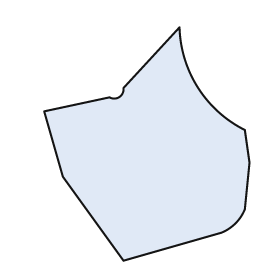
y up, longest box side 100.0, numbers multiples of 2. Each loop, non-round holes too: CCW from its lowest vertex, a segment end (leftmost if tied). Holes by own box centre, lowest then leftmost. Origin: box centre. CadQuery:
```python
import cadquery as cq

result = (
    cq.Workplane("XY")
    .moveTo(-10.0, -50.0)
    .lineTo(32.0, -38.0)
    .threePointArc((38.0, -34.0), (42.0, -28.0))
    .lineTo(44.0, -8.0)
    .lineTo(42.0, 6.0)
    .threePointArc((22.0, 24.0), (14.0, 50.0))
    .lineTo(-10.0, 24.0)
    .threePointArc((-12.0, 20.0), (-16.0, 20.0))
    .lineTo(-44.0, 14.0)
    .lineTo(-36.0, -14.0)
    .close()
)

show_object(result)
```